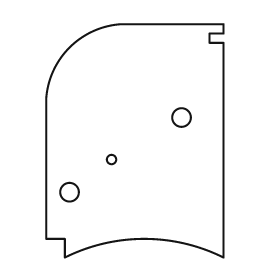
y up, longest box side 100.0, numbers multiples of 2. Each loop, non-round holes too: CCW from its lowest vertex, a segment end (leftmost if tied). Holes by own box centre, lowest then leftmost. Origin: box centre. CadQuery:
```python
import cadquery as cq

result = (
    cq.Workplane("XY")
    .moveTo(-30.0, -50.0)
    .threePointArc((4.0, -42.0), (38.0, -50.0))
    .lineTo(38.0, 42.0)
    .lineTo(32.0, 42.0)
    .lineTo(32.0, 46.0)
    .lineTo(38.0, 46.0)
    .lineTo(38.0, 50.0)
    .lineTo(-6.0, 50.0)
    .threePointArc((-28.0, 40.0), (-38.0, 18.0))
    .lineTo(-38.0, -42.0)
    .lineTo(-30.0, -42.0)
    .close()
    .moveTo(-28.0, -22.0)
    .circle(4.0)
    .moveTo(-10.0, -8.0)
    .circle(2.0)
    .moveTo(20.0, 10.0)
    .circle(4.0)
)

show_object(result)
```